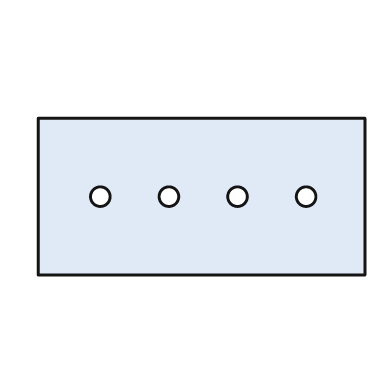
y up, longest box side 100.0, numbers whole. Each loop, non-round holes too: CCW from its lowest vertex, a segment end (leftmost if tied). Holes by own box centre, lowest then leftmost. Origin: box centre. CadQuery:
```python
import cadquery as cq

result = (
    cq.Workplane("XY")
    .moveTo(-50.0, -24.0)
    .lineTo(50.0, -24.0)
    .lineTo(50.0, 24.0)
    .lineTo(-50.0, 24.0)
    .close()
    .moveTo(-31.0, 0.0)
    .circle(3.0)
    .moveTo(-10.0, 0.0)
    .circle(3.0)
    .moveTo(11.0, 0.0)
    .circle(3.0)
    .moveTo(32.0, 0.0)
    .circle(3.0)
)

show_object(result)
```